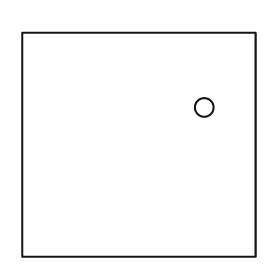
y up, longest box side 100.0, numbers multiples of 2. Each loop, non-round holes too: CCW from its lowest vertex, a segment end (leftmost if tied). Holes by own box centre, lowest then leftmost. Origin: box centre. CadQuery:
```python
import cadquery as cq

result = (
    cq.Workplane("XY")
    .moveTo(-50.0, -48.0)
    .lineTo(50.0, -48.0)
    .lineTo(50.0, 48.0)
    .lineTo(-50.0, 48.0)
    .close()
    .moveTo(28.0, 16.0)
    .circle(4.0)
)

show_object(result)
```